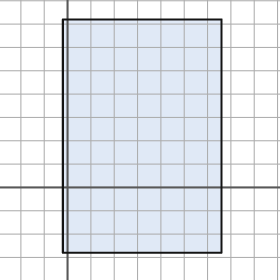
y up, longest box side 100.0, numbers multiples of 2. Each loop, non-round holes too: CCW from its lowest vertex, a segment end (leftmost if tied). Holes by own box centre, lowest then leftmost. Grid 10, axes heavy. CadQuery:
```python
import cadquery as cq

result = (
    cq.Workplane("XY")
    .moveTo(-2.0, -28.0)
    .lineTo(66.0, -28.0)
    .lineTo(66.0, 72.0)
    .lineTo(-2.0, 72.0)
    .close()
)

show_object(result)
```